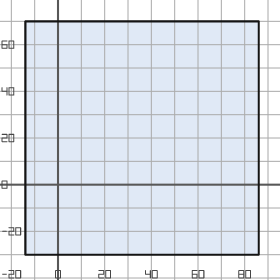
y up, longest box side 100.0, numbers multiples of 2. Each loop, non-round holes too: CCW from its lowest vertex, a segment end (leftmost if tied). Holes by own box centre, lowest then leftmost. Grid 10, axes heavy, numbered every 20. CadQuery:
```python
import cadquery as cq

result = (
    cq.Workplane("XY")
    .moveTo(-14.0, -30.0)
    .lineTo(86.0, -30.0)
    .lineTo(86.0, 70.0)
    .lineTo(-14.0, 70.0)
    .close()
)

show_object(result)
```